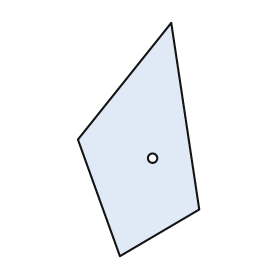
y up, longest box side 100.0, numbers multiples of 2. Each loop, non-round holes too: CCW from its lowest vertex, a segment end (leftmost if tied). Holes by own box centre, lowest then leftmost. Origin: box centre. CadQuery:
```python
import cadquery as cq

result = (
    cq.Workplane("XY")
    .moveTo(-8.0, -50.0)
    .lineTo(26.0, -30.0)
    .lineTo(14.0, 50.0)
    .lineTo(-26.0, 0.0)
    .close()
    .moveTo(6.0, -8.0)
    .circle(2.0)
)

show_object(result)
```